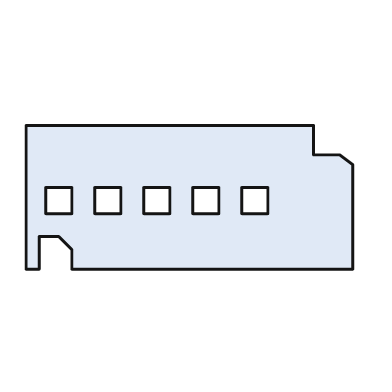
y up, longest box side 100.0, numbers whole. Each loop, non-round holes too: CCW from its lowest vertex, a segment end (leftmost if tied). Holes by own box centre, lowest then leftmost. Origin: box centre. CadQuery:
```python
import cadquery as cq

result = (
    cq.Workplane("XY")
    .moveTo(-50.0, -22.0)
    .lineTo(-46.0, -22.0)
    .lineTo(-46.0, -12.0)
    .lineTo(-40.0, -12.0)
    .lineTo(-36.0, -16.0)
    .lineTo(-36.0, -22.0)
    .lineTo(50.0, -22.0)
    .lineTo(50.0, 10.0)
    .lineTo(46.0, 13.0)
    .lineTo(38.0, 13.0)
    .lineTo(38.0, 22.0)
    .lineTo(-50.0, 22.0)
    .close()
    .moveTo(-44.0, -5.0)
    .lineTo(-36.0, -5.0)
    .lineTo(-36.0, 3.0)
    .lineTo(-44.0, 3.0)
    .close()
    .moveTo(-29.0, -5.0)
    .lineTo(-21.0, -5.0)
    .lineTo(-21.0, 3.0)
    .lineTo(-29.0, 3.0)
    .close()
    .moveTo(-14.0, -5.0)
    .lineTo(-6.0, -5.0)
    .lineTo(-6.0, 3.0)
    .lineTo(-14.0, 3.0)
    .close()
    .moveTo(1.0, -5.0)
    .lineTo(9.0, -5.0)
    .lineTo(9.0, 3.0)
    .lineTo(1.0, 3.0)
    .close()
    .moveTo(16.0, -5.0)
    .lineTo(24.0, -5.0)
    .lineTo(24.0, 3.0)
    .lineTo(16.0, 3.0)
    .close()
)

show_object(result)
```